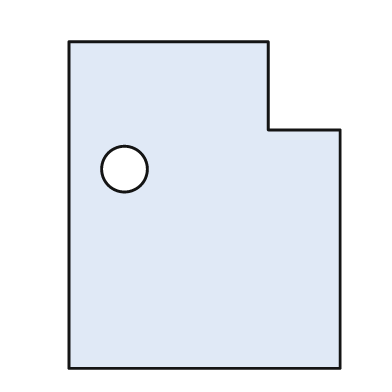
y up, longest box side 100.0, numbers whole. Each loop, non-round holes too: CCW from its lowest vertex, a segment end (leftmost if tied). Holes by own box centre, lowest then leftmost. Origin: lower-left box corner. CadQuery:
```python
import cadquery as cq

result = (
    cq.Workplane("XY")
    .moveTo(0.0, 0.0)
    .lineTo(83.0, 0.0)
    .lineTo(83.0, 73.0)
    .lineTo(61.0, 73.0)
    .lineTo(61.0, 100.0)
    .lineTo(0.0, 100.0)
    .close()
    .moveTo(17.0, 61.0)
    .circle(7.0)
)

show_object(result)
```